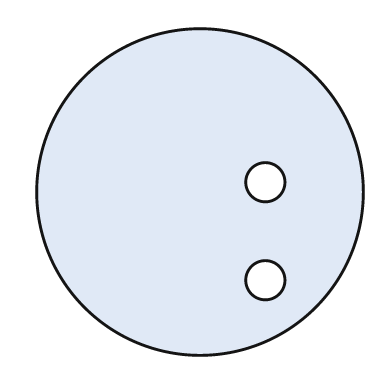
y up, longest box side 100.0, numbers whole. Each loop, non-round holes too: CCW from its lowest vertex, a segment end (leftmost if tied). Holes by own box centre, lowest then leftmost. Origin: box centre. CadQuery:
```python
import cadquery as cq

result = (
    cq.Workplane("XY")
    .moveTo(0.0, 0.0)
    .circle(50.0)
    .moveTo(20.0, -27.0)
    .circle(6.0)
    .moveTo(20.0, 3.0)
    .circle(6.0)
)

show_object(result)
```